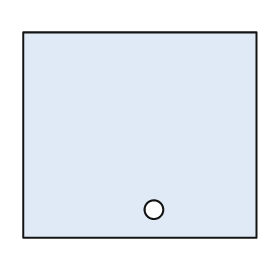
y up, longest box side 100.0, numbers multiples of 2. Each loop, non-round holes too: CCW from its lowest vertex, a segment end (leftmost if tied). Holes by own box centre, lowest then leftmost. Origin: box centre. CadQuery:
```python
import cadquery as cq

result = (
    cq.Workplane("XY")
    .moveTo(-50.0, -44.0)
    .lineTo(50.0, -44.0)
    .lineTo(50.0, 44.0)
    .lineTo(-50.0, 44.0)
    .close()
    .moveTo(6.0, -32.0)
    .circle(4.0)
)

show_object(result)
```